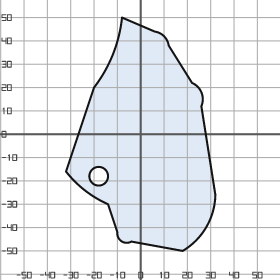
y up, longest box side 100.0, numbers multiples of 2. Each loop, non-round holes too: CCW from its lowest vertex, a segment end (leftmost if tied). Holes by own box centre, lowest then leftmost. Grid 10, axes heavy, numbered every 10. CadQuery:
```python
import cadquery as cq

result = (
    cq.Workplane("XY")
    .moveTo(18.0, -50.0)
    .threePointArc((28.0, -40.0), (32.0, -26.0))
    .lineTo(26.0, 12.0)
    .threePointArc((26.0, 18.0), (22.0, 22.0))
    .lineTo(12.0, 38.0)
    .threePointArc((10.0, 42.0), (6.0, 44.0))
    .lineTo(-8.0, 50.0)
    .threePointArc((-12.0, 34.0), (-20.0, 20.0))
    .lineTo(-32.0, -16.0)
    .threePointArc((-24.0, -24.0), (-14.0, -30.0))
    .lineTo(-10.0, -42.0)
    .threePointArc((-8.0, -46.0), (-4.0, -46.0))
    .close()
    .moveTo(-18.0, -18.0)
    .circle(4.0)
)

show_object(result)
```